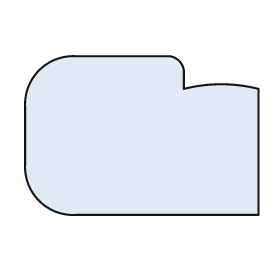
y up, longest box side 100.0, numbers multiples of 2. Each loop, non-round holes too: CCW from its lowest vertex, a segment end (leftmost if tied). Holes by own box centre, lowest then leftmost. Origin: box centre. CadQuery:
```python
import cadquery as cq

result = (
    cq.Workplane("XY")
    .moveTo(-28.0, -34.0)
    .lineTo(50.0, -34.0)
    .lineTo(50.0, 20.0)
    .threePointArc((34.0, 22.0), (18.0, 20.0))
    .lineTo(18.0, 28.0)
    .threePointArc((16.0, 32.0), (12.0, 34.0))
    .lineTo(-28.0, 34.0)
    .threePointArc((-44.0, 28.0), (-50.0, 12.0))
    .lineTo(-50.0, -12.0)
    .threePointArc((-44.0, -28.0), (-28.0, -34.0))
    .close()
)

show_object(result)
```